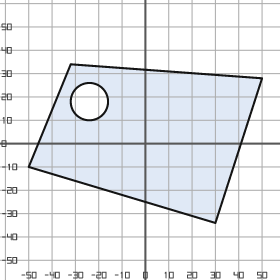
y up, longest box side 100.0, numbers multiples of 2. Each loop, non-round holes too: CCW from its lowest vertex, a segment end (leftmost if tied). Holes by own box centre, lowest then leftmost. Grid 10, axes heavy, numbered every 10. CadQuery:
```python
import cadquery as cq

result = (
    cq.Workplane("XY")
    .moveTo(30.0, -34.0)
    .lineTo(50.0, 28.0)
    .lineTo(-32.0, 34.0)
    .lineTo(-50.0, -10.0)
    .close()
    .moveTo(-24.0, 18.0)
    .circle(8.0)
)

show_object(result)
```